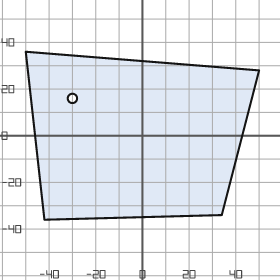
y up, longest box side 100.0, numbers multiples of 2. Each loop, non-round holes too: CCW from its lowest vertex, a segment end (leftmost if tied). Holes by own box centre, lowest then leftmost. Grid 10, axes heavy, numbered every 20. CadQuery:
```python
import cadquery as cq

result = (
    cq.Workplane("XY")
    .moveTo(-42.0, -36.0)
    .lineTo(34.0, -34.0)
    .lineTo(50.0, 28.0)
    .lineTo(-50.0, 36.0)
    .close()
    .moveTo(-30.0, 16.0)
    .circle(2.0)
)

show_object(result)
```